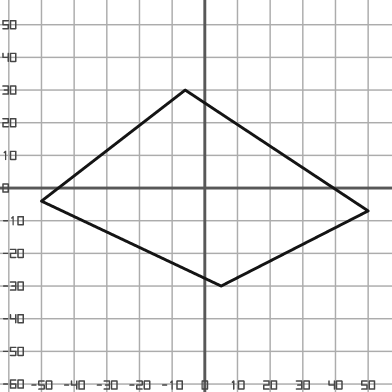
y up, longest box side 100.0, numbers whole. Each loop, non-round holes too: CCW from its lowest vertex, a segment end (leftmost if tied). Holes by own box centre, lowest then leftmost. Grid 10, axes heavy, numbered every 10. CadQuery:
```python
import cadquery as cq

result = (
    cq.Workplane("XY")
    .moveTo(5.0, -30.0)
    .lineTo(50.0, -7.0)
    .lineTo(-6.0, 30.0)
    .lineTo(-50.0, -4.0)
    .close()
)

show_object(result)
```